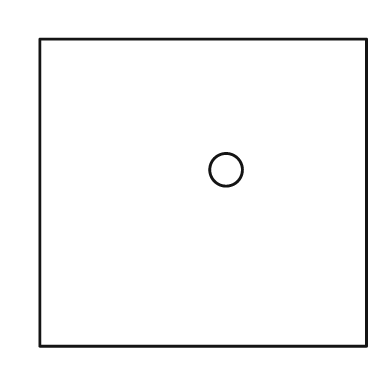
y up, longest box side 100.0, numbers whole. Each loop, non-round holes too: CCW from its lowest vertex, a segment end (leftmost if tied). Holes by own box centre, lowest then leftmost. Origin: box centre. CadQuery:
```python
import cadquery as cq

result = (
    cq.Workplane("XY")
    .moveTo(-50.0, -47.0)
    .lineTo(50.0, -47.0)
    .lineTo(50.0, 47.0)
    .lineTo(-50.0, 47.0)
    .close()
    .moveTo(7.0, 7.0)
    .circle(5.0)
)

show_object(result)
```